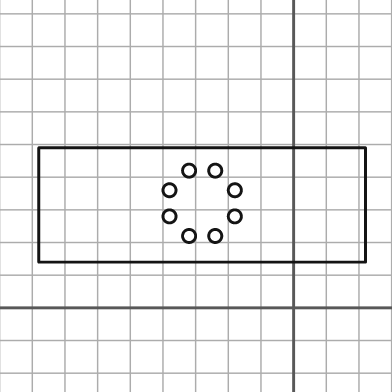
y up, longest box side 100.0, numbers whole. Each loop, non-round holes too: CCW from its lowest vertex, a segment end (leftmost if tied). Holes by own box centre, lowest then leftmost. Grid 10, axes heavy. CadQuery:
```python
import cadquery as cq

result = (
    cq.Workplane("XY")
    .moveTo(-78.0, 14.0)
    .lineTo(22.0, 14.0)
    .lineTo(22.0, 49.0)
    .lineTo(-78.0, 49.0)
    .close()
    .moveTo(-32.0, 22.0)
    .circle(2.0)
    .moveTo(-24.0, 22.0)
    .circle(2.0)
    .moveTo(-38.0, 28.0)
    .circle(2.0)
    .moveTo(-18.0, 28.0)
    .circle(2.0)
    .moveTo(-38.0, 36.0)
    .circle(2.0)
    .moveTo(-18.0, 36.0)
    .circle(2.0)
    .moveTo(-32.0, 42.0)
    .circle(2.0)
    .moveTo(-24.0, 42.0)
    .circle(2.0)
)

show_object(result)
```